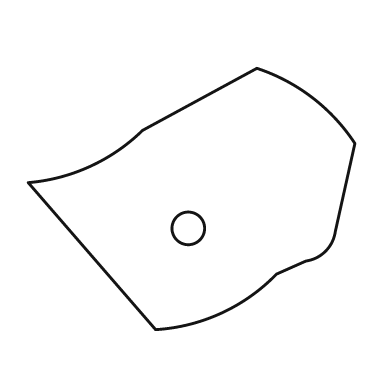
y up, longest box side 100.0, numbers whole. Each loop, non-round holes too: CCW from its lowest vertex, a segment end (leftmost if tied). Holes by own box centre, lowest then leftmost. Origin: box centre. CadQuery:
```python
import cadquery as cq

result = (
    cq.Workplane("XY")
    .moveTo(-11.0, -40.0)
    .threePointArc((9.0, -35.0), (26.0, -23.0))
    .lineTo(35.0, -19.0)
    .threePointArc((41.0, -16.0), (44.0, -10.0))
    .lineTo(50.0, 17.0)
    .threePointArc((37.0, 31.0), (20.0, 40.0))
    .lineTo(-15.0, 21.0)
    .threePointArc((-31.0, 10.0), (-50.0, 5.0))
    .close()
    .moveTo(-1.0, -9.0)
    .circle(5.0)
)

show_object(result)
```